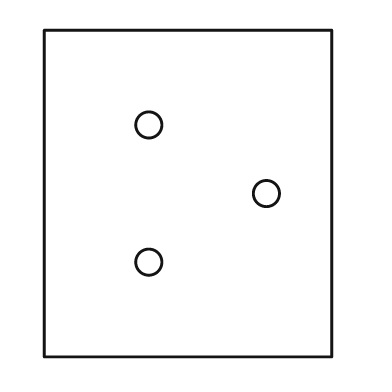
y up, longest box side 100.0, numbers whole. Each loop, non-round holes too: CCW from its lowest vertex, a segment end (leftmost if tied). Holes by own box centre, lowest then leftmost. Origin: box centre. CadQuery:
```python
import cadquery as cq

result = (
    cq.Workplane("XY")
    .moveTo(-44.0, -50.0)
    .lineTo(44.0, -50.0)
    .lineTo(44.0, 50.0)
    .lineTo(-44.0, 50.0)
    .close()
    .moveTo(-12.0, -21.0)
    .circle(4.0)
    .moveTo(24.0, 0.0)
    .circle(4.0)
    .moveTo(-12.0, 21.0)
    .circle(4.0)
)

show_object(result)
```